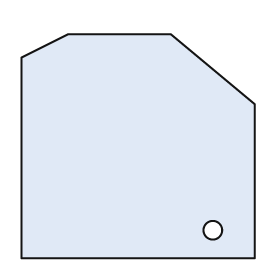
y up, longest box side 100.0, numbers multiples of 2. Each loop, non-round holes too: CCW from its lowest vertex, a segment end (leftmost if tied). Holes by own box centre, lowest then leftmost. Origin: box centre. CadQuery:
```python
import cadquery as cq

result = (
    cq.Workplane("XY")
    .moveTo(-50.0, -48.0)
    .lineTo(50.0, -48.0)
    .lineTo(50.0, 18.0)
    .lineTo(14.0, 48.0)
    .lineTo(-30.0, 48.0)
    .lineTo(-50.0, 38.0)
    .close()
    .moveTo(32.0, -36.0)
    .circle(4.0)
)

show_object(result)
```